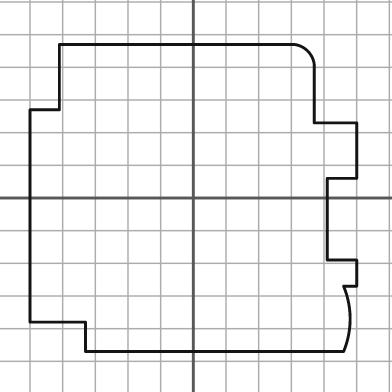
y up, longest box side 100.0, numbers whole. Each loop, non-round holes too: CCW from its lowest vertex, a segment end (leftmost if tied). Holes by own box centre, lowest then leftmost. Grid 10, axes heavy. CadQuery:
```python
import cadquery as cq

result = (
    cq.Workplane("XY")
    .moveTo(-33.0, -47.0)
    .lineTo(46.0, -47.0)
    .threePointArc((48.0, -37.0), (46.0, -27.0))
    .lineTo(50.0, -27.0)
    .lineTo(50.0, -19.0)
    .lineTo(41.0, -19.0)
    .lineTo(41.0, 6.0)
    .lineTo(50.0, 6.0)
    .lineTo(50.0, 23.0)
    .lineTo(37.0, 23.0)
    .lineTo(37.0, 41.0)
    .threePointArc((35.0, 45.0), (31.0, 47.0))
    .lineTo(-41.0, 47.0)
    .lineTo(-41.0, 27.0)
    .lineTo(-50.0, 27.0)
    .lineTo(-50.0, -38.0)
    .lineTo(-33.0, -38.0)
    .close()
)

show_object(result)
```